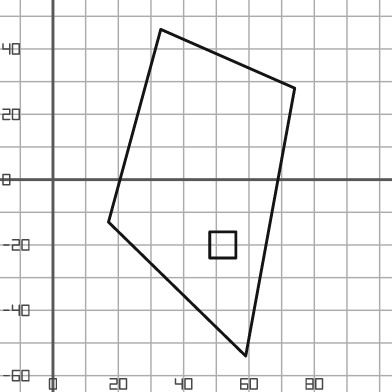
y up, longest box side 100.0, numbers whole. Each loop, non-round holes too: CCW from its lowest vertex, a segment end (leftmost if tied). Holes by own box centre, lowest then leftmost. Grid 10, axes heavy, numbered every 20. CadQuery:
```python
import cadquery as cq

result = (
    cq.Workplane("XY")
    .moveTo(59.0, -54.0)
    .lineTo(74.0, 28.0)
    .lineTo(33.0, 46.0)
    .lineTo(17.0, -13.0)
    .close()
    .moveTo(48.0, -24.0)
    .lineTo(56.0, -24.0)
    .lineTo(56.0, -16.0)
    .lineTo(48.0, -16.0)
    .close()
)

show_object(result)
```